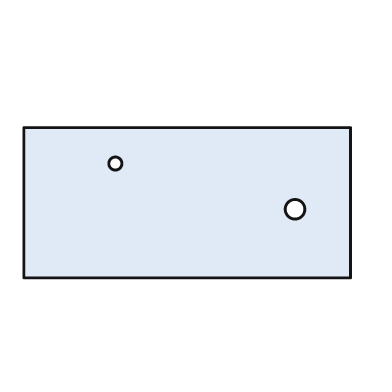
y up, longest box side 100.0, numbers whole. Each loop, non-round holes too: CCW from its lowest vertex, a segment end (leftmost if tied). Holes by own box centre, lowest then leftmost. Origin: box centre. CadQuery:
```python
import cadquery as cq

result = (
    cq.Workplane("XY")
    .moveTo(-50.0, -23.0)
    .lineTo(50.0, -23.0)
    .lineTo(50.0, 23.0)
    .lineTo(-50.0, 23.0)
    .close()
    .moveTo(33.0, -2.0)
    .circle(3.0)
    .moveTo(-22.0, 12.0)
    .circle(2.0)
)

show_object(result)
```